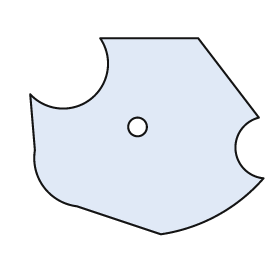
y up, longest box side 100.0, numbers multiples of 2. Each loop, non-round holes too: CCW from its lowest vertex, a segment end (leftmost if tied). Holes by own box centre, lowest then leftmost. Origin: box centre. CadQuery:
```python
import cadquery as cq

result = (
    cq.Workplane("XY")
    .moveTo(6.0, -42.0)
    .threePointArc((30.0, -34.0), (50.0, -18.0))
    .threePointArc((38.0, -6.0), (48.0, 8.0))
    .lineTo(22.0, 42.0)
    .lineTo(-20.0, 42.0)
    .threePointArc((-24.0, 16.0), (-50.0, 18.0))
    .lineTo(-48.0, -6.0)
    .threePointArc((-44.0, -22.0), (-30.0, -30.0))
    .close()
    .moveTo(-4.0, 4.0)
    .circle(4.0)
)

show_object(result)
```